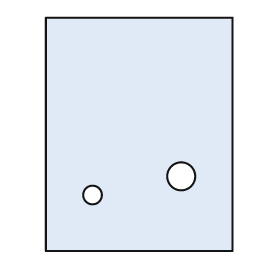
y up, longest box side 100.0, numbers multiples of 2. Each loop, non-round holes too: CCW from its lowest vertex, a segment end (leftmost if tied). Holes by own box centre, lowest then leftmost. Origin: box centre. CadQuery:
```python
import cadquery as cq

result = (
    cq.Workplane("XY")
    .moveTo(-40.0, -50.0)
    .lineTo(40.0, -50.0)
    .lineTo(40.0, 50.0)
    .lineTo(-40.0, 50.0)
    .close()
    .moveTo(-20.0, -26.0)
    .circle(4.0)
    .moveTo(18.0, -18.0)
    .circle(6.0)
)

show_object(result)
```